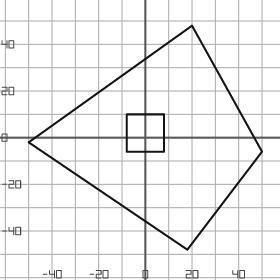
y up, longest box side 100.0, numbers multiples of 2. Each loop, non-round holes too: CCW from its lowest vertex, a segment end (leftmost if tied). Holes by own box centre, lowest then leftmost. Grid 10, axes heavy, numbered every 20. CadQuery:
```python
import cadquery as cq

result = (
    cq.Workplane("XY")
    .moveTo(18.0, -48.0)
    .lineTo(50.0, -6.0)
    .lineTo(20.0, 48.0)
    .lineTo(-50.0, -2.0)
    .close()
    .moveTo(-8.0, -6.0)
    .lineTo(8.0, -6.0)
    .lineTo(8.0, 10.0)
    .lineTo(-8.0, 10.0)
    .close()
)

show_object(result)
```